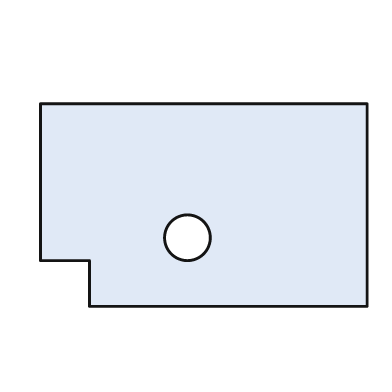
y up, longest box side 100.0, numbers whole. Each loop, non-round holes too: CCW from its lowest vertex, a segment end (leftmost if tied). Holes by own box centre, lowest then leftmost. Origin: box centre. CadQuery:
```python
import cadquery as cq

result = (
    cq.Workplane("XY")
    .moveTo(-35.0, -31.0)
    .lineTo(50.0, -31.0)
    .lineTo(50.0, 31.0)
    .lineTo(-50.0, 31.0)
    .lineTo(-50.0, -17.0)
    .lineTo(-35.0, -17.0)
    .close()
    .moveTo(-5.0, -10.0)
    .circle(7.0)
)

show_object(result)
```